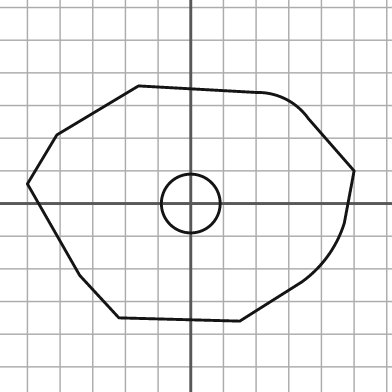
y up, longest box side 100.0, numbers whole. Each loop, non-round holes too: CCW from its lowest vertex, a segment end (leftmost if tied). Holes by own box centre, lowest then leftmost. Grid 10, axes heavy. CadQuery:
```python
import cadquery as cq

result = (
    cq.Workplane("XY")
    .moveTo(15.0, -36.0)
    .lineTo(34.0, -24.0)
    .threePointArc((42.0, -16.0), (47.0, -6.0))
    .lineTo(50.0, 10.0)
    .lineTo(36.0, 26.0)
    .threePointArc((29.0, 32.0), (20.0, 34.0))
    .lineTo(-16.0, 36.0)
    .lineTo(-41.0, 21.0)
    .lineTo(-50.0, 6.0)
    .lineTo(-34.0, -22.0)
    .lineTo(-22.0, -35.0)
    .close()
    .moveTo(0.0, 0.0)
    .circle(9.0)
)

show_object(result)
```